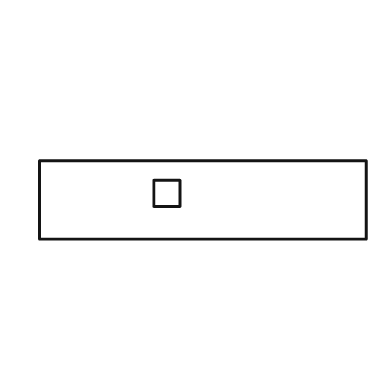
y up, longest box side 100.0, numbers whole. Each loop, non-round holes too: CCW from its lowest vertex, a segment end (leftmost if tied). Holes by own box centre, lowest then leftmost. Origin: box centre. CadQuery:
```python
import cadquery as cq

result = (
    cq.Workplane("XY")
    .moveTo(-50.0, -12.0)
    .lineTo(50.0, -12.0)
    .lineTo(50.0, 12.0)
    .lineTo(-50.0, 12.0)
    .close()
    .moveTo(-15.0, -2.0)
    .lineTo(-7.0, -2.0)
    .lineTo(-7.0, 6.0)
    .lineTo(-15.0, 6.0)
    .close()
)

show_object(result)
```